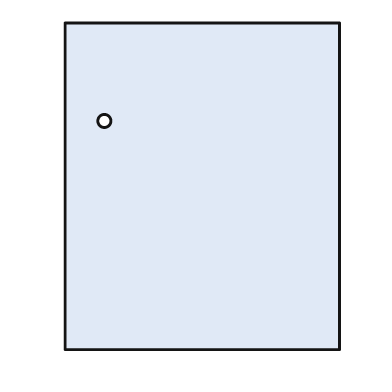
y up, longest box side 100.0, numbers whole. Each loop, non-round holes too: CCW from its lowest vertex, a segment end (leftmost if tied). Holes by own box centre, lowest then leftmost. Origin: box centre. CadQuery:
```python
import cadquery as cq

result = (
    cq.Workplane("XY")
    .moveTo(-42.0, -50.0)
    .lineTo(42.0, -50.0)
    .lineTo(42.0, 50.0)
    .lineTo(-42.0, 50.0)
    .close()
    .moveTo(-30.0, 20.0)
    .circle(2.0)
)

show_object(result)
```